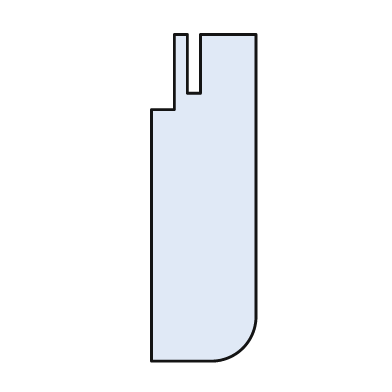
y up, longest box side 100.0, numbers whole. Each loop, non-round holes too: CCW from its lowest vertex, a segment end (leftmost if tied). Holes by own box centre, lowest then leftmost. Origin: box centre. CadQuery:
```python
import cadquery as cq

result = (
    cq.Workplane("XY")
    .moveTo(-16.0, -50.0)
    .lineTo(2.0, -50.0)
    .threePointArc((12.0, -46.0), (16.0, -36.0))
    .lineTo(16.0, 50.0)
    .lineTo(-1.0, 50.0)
    .lineTo(-1.0, 32.0)
    .lineTo(-5.0, 32.0)
    .lineTo(-5.0, 50.0)
    .lineTo(-9.0, 50.0)
    .lineTo(-9.0, 27.0)
    .lineTo(-16.0, 27.0)
    .close()
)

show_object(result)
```